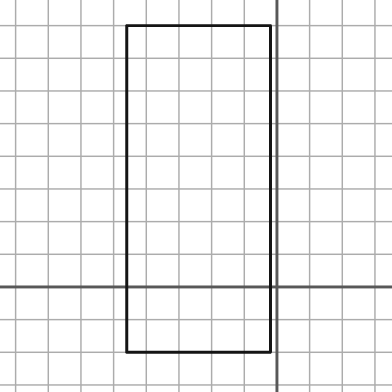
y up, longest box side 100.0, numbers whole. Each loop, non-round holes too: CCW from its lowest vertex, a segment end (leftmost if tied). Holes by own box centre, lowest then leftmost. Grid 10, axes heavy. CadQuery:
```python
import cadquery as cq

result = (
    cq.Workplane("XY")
    .moveTo(-46.0, -20.0)
    .lineTo(-2.0, -20.0)
    .lineTo(-2.0, 80.0)
    .lineTo(-46.0, 80.0)
    .close()
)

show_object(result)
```